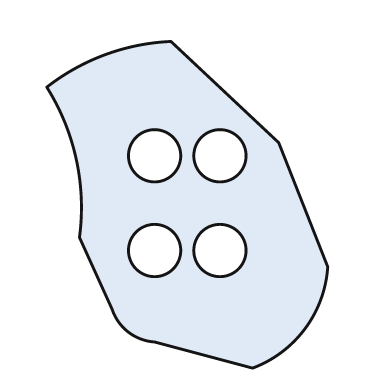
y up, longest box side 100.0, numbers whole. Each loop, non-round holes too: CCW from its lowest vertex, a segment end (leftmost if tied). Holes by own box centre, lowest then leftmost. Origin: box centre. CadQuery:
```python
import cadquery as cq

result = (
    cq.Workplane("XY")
    .moveTo(20.0, -50.0)
    .threePointArc((36.0, -38.0), (43.0, -19.0))
    .lineTo(28.0, 19.0)
    .lineTo(-5.0, 50.0)
    .threePointArc((-25.0, 46.0), (-43.0, 36.0))
    .threePointArc((-34.0, 14.0), (-33.0, -10.0))
    .lineTo(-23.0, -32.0)
    .threePointArc((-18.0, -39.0), (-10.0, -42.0))
    .close()
    .moveTo(-10.0, -14.0)
    .circle(8.0)
    .moveTo(10.0, -14.0)
    .circle(8.0)
    .moveTo(-10.0, 15.0)
    .circle(8.0)
    .moveTo(10.0, 15.0)
    .circle(8.0)
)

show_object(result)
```